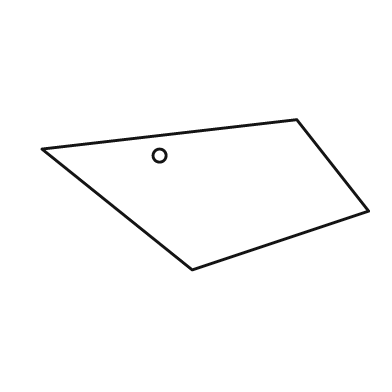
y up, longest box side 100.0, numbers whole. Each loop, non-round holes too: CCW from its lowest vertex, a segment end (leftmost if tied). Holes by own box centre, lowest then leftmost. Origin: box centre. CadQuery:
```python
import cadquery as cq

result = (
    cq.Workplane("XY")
    .moveTo(-4.0, -23.0)
    .lineTo(50.0, -5.0)
    .lineTo(28.0, 23.0)
    .lineTo(-50.0, 14.0)
    .close()
    .moveTo(-14.0, 12.0)
    .circle(2.0)
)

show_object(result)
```